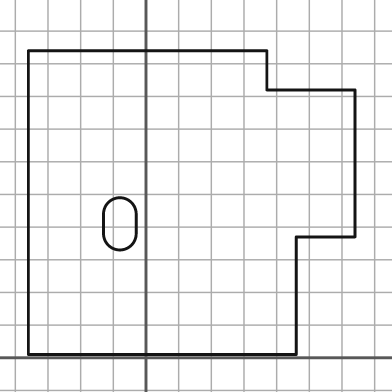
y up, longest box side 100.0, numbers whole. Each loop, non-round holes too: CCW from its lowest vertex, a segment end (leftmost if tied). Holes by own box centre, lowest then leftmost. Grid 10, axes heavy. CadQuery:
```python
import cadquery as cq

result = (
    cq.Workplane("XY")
    .moveTo(-36.0, 1.0)
    .lineTo(46.0, 1.0)
    .lineTo(46.0, 37.0)
    .lineTo(64.0, 37.0)
    .lineTo(64.0, 82.0)
    .lineTo(37.0, 82.0)
    .lineTo(37.0, 94.0)
    .lineTo(-36.0, 94.0)
    .close()
    .moveTo(-13.0, 38.0)
    .threePointArc((-8.0, 33.0), (-3.0, 38.0))
    .lineTo(-3.0, 44.0)
    .threePointArc((-8.0, 49.0), (-13.0, 44.0))
    .close()
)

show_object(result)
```